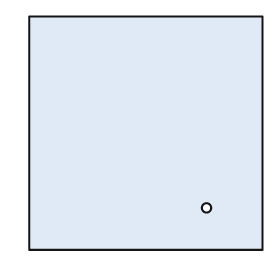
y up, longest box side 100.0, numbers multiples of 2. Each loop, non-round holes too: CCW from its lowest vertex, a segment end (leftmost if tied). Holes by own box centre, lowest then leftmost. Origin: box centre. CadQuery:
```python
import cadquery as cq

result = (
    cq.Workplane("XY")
    .moveTo(-50.0, -50.0)
    .lineTo(50.0, -50.0)
    .lineTo(50.0, 50.0)
    .lineTo(-50.0, 50.0)
    .close()
    .moveTo(26.0, -32.0)
    .circle(2.0)
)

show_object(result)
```